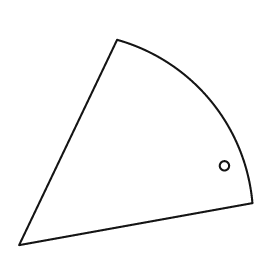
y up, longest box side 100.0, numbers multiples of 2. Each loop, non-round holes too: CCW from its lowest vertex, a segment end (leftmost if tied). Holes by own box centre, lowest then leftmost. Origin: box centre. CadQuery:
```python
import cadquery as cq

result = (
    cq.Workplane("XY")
    .moveTo(-50.0, -44.0)
    .lineTo(50.0, -26.0)
    .threePointArc((32.0, 18.0), (-8.0, 44.0))
    .close()
    .moveTo(38.0, -10.0)
    .circle(2.0)
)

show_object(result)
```